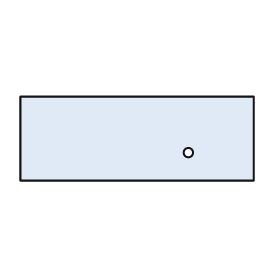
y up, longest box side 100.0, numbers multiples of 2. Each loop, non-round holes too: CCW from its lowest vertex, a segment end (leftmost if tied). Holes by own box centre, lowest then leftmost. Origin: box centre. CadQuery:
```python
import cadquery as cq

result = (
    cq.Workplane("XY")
    .moveTo(-50.0, -18.0)
    .lineTo(50.0, -18.0)
    .lineTo(50.0, 18.0)
    .lineTo(-50.0, 18.0)
    .close()
    .moveTo(22.0, -6.0)
    .circle(2.0)
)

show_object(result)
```